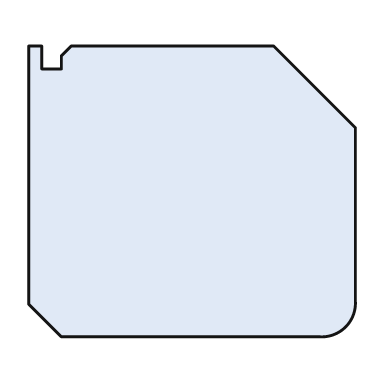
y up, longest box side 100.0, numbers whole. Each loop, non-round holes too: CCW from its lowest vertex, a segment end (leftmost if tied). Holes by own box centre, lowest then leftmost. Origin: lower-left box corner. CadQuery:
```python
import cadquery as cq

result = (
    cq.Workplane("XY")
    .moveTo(10.0, 0.0)
    .lineTo(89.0, 0.0)
    .threePointArc((97.0, 3.0), (100.0, 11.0))
    .lineTo(100.0, 64.0)
    .lineTo(75.0, 89.0)
    .lineTo(13.0, 89.0)
    .lineTo(10.0, 86.0)
    .lineTo(10.0, 82.0)
    .lineTo(4.0, 82.0)
    .lineTo(4.0, 89.0)
    .lineTo(0.0, 89.0)
    .lineTo(0.0, 10.0)
    .close()
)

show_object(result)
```